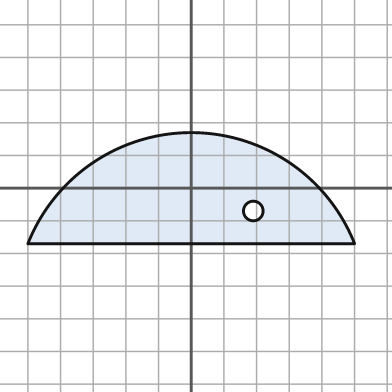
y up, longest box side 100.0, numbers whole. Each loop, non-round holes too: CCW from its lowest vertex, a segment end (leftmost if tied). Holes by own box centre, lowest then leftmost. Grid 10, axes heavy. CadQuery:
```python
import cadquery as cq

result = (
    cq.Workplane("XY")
    .moveTo(-50.0, -17.0)
    .lineTo(50.0, -17.0)
    .threePointArc((0.0, 17.0), (-50.0, -17.0))
    .close()
    .moveTo(19.0, -7.0)
    .circle(3.0)
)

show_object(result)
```